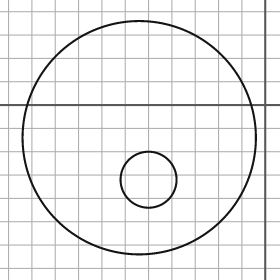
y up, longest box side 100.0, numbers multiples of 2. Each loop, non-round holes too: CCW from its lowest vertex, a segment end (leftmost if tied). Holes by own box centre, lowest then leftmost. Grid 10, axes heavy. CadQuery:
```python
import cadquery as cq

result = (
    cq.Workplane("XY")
    .moveTo(-54.0, -14.0)
    .circle(50.0)
    .moveTo(-50.0, -32.0)
    .circle(12.0)
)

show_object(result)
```